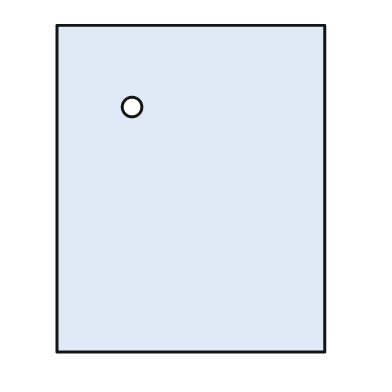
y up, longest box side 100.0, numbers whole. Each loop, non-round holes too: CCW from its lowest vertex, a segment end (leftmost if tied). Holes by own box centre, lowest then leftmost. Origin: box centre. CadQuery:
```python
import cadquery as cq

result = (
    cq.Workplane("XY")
    .moveTo(-41.0, -50.0)
    .lineTo(41.0, -50.0)
    .lineTo(41.0, 50.0)
    .lineTo(-41.0, 50.0)
    .close()
    .moveTo(-18.0, 25.0)
    .circle(3.0)
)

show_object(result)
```